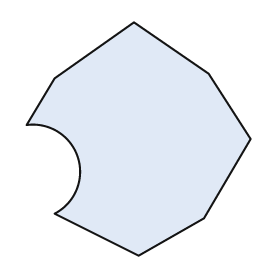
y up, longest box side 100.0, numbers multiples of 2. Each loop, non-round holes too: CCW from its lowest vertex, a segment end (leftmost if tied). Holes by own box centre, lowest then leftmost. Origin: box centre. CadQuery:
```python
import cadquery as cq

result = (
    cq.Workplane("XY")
    .moveTo(0.0, -50.0)
    .lineTo(28.0, -34.0)
    .lineTo(48.0, 0.0)
    .lineTo(30.0, 28.0)
    .lineTo(-2.0, 50.0)
    .lineTo(-36.0, 26.0)
    .lineTo(-48.0, 6.0)
    .threePointArc((-26.0, -8.0), (-36.0, -32.0))
    .close()
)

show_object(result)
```